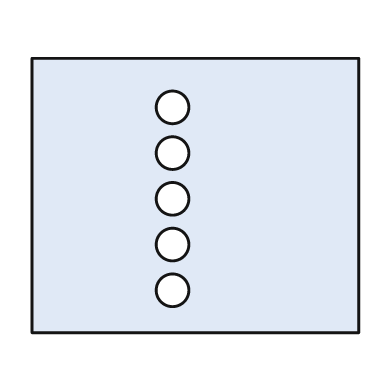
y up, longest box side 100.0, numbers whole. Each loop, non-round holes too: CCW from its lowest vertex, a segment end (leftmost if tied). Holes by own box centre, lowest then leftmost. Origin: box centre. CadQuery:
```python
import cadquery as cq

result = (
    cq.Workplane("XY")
    .moveTo(-50.0, -42.0)
    .lineTo(50.0, -42.0)
    .lineTo(50.0, 42.0)
    .lineTo(-50.0, 42.0)
    .close()
    .moveTo(-7.0, -29.0)
    .circle(5.0)
    .moveTo(-7.0, -15.0)
    .circle(5.0)
    .moveTo(-7.0, -1.0)
    .circle(5.0)
    .moveTo(-7.0, 13.0)
    .circle(5.0)
    .moveTo(-7.0, 27.0)
    .circle(5.0)
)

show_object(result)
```